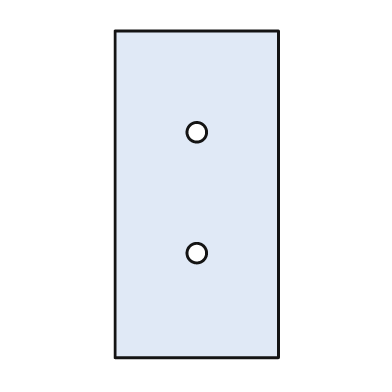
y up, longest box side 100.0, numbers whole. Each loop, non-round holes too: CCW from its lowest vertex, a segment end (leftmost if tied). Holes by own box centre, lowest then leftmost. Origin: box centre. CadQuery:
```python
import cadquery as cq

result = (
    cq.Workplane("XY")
    .moveTo(-25.0, -50.0)
    .lineTo(25.0, -50.0)
    .lineTo(25.0, 50.0)
    .lineTo(-25.0, 50.0)
    .close()
    .moveTo(0.0, -18.0)
    .circle(3.0)
    .moveTo(0.0, 19.0)
    .circle(3.0)
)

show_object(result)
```